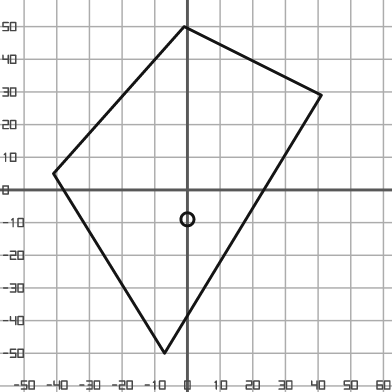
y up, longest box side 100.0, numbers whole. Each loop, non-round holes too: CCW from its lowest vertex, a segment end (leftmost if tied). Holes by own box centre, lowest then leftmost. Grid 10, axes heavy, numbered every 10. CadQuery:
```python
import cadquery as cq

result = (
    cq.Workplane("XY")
    .moveTo(-7.0, -50.0)
    .lineTo(41.0, 29.0)
    .lineTo(-1.0, 50.0)
    .lineTo(-41.0, 5.0)
    .close()
    .moveTo(0.0, -9.0)
    .circle(2.0)
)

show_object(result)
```